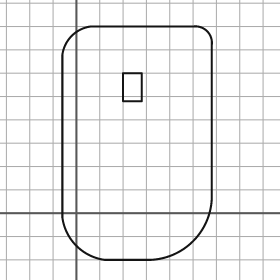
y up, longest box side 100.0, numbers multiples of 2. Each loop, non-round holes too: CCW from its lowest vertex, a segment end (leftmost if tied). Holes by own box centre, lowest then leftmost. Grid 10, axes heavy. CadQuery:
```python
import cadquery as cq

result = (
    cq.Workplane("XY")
    .moveTo(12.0, -20.0)
    .lineTo(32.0, -20.0)
    .threePointArc((50.0, -12.0), (58.0, 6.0))
    .lineTo(58.0, 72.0)
    .threePointArc((56.0, 78.0), (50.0, 80.0))
    .lineTo(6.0, 80.0)
    .threePointArc((-2.0, 76.0), (-6.0, 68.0))
    .lineTo(-6.0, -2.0)
    .threePointArc((0.0, -14.0), (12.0, -20.0))
    .close()
    .moveTo(20.0, 48.0)
    .lineTo(28.0, 48.0)
    .lineTo(28.0, 60.0)
    .lineTo(20.0, 60.0)
    .close()
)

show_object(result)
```